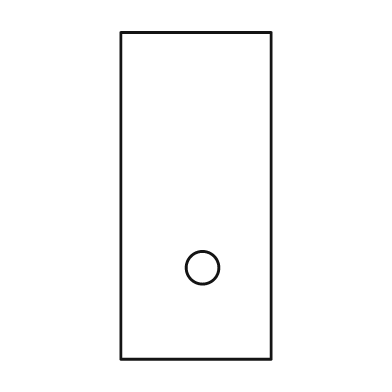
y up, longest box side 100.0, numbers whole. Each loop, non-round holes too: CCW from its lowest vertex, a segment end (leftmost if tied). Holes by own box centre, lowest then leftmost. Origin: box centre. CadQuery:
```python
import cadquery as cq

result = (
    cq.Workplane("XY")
    .moveTo(-23.0, -50.0)
    .lineTo(23.0, -50.0)
    .lineTo(23.0, 50.0)
    .lineTo(-23.0, 50.0)
    .close()
    .moveTo(2.0, -22.0)
    .circle(5.0)
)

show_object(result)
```